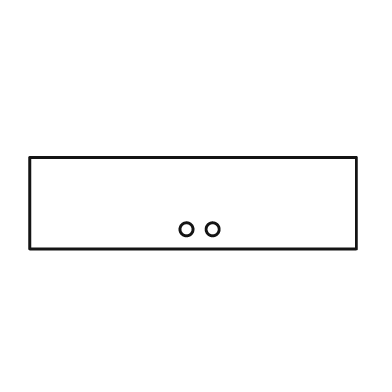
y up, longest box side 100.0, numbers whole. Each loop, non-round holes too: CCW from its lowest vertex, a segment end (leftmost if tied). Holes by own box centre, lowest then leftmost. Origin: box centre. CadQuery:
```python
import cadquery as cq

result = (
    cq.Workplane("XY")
    .moveTo(-50.0, -14.0)
    .lineTo(50.0, -14.0)
    .lineTo(50.0, 14.0)
    .lineTo(-50.0, 14.0)
    .close()
    .moveTo(-2.0, -8.0)
    .circle(2.0)
    .moveTo(6.0, -8.0)
    .circle(2.0)
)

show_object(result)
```